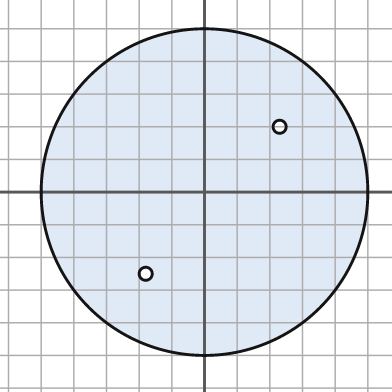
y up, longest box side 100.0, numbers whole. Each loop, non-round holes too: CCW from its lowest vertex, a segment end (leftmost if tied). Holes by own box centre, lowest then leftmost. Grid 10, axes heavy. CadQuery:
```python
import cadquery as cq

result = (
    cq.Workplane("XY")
    .moveTo(0.0, 0.0)
    .circle(50.0)
    .moveTo(-18.0, -25.0)
    .circle(2.0)
    .moveTo(23.0, 20.0)
    .circle(2.0)
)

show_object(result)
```